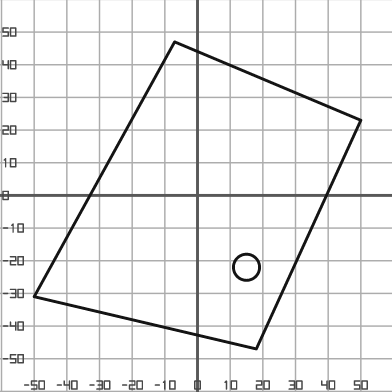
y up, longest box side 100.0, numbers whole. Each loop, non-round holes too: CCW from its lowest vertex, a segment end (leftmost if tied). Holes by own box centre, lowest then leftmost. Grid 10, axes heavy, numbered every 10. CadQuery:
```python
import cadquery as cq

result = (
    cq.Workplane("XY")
    .moveTo(18.0, -47.0)
    .lineTo(50.0, 23.0)
    .lineTo(-7.0, 47.0)
    .lineTo(-50.0, -31.0)
    .close()
    .moveTo(15.0, -22.0)
    .circle(4.0)
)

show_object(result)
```